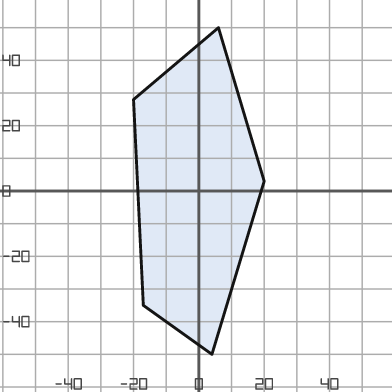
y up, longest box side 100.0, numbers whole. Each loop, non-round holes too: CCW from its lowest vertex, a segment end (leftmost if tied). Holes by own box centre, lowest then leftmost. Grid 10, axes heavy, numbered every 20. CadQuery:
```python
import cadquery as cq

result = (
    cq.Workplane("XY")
    .moveTo(4.0, -50.0)
    .lineTo(20.0, 3.0)
    .lineTo(6.0, 50.0)
    .lineTo(-20.0, 28.0)
    .lineTo(-17.0, -35.0)
    .close()
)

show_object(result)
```